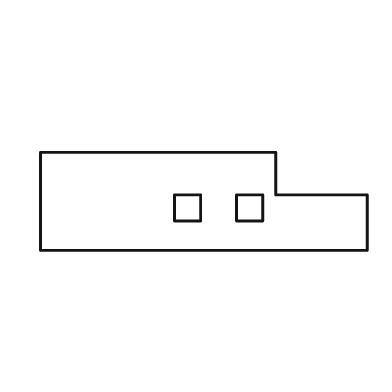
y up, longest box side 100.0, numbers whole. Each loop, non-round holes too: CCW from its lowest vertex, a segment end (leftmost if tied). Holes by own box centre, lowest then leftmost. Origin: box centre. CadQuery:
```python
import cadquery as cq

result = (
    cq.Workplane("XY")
    .moveTo(-50.0, -15.0)
    .lineTo(50.0, -15.0)
    .lineTo(50.0, 2.0)
    .lineTo(22.0, 2.0)
    .lineTo(22.0, 15.0)
    .lineTo(-50.0, 15.0)
    .close()
    .moveTo(-9.0, -6.0)
    .lineTo(-1.0, -6.0)
    .lineTo(-1.0, 2.0)
    .lineTo(-9.0, 2.0)
    .close()
    .moveTo(10.0, -6.0)
    .lineTo(18.0, -6.0)
    .lineTo(18.0, 2.0)
    .lineTo(10.0, 2.0)
    .close()
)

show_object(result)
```